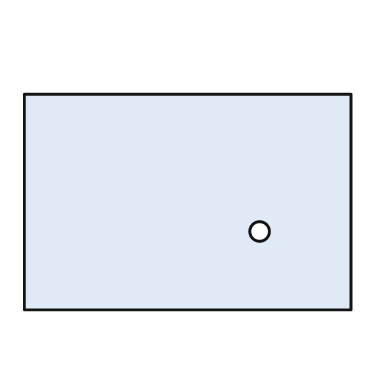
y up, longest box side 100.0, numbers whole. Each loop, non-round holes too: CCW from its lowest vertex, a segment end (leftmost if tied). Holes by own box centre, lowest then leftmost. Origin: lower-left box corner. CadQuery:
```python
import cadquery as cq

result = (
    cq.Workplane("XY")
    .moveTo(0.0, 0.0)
    .lineTo(100.0, 0.0)
    .lineTo(100.0, 66.0)
    .lineTo(0.0, 66.0)
    .close()
    .moveTo(72.0, 24.0)
    .circle(3.0)
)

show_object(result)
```